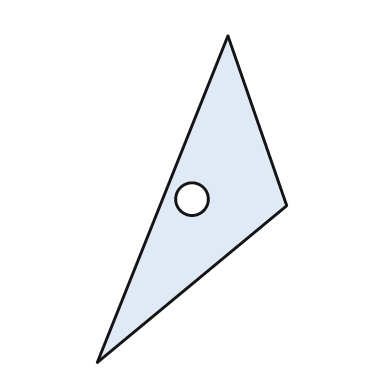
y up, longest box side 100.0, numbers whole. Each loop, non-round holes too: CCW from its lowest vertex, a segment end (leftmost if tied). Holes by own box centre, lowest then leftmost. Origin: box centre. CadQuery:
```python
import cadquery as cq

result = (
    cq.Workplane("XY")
    .moveTo(-29.0, -50.0)
    .lineTo(29.0, -2.0)
    .lineTo(11.0, 50.0)
    .close()
    .moveTo(0.0, 0.0)
    .circle(5.0)
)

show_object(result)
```